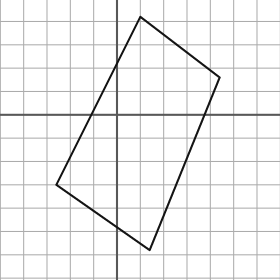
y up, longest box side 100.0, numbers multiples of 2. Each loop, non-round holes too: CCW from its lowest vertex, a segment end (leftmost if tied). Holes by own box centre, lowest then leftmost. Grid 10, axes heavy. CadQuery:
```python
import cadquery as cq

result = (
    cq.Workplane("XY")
    .moveTo(14.0, -58.0)
    .lineTo(44.0, 16.0)
    .lineTo(10.0, 42.0)
    .lineTo(-26.0, -30.0)
    .close()
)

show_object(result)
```